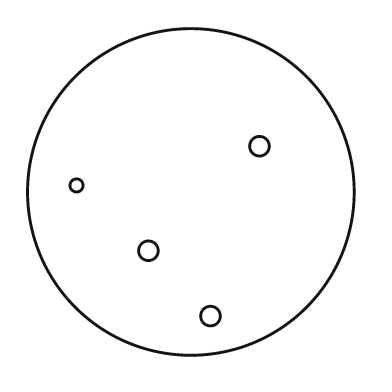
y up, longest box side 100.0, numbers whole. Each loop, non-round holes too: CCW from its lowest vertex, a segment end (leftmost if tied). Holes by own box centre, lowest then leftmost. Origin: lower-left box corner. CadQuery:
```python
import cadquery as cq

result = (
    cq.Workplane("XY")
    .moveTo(50.0, 50.0)
    .circle(50.0)
    .moveTo(56.0, 12.0)
    .circle(3.0)
    .moveTo(37.0, 32.0)
    .circle(3.0)
    .moveTo(15.0, 52.0)
    .circle(2.0)
    .moveTo(71.0, 64.0)
    .circle(3.0)
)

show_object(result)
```